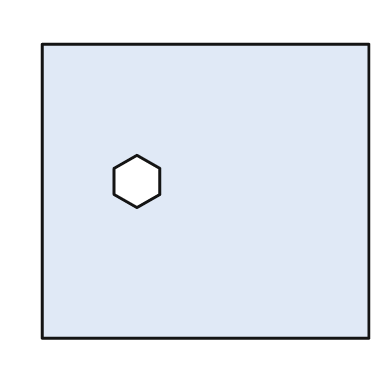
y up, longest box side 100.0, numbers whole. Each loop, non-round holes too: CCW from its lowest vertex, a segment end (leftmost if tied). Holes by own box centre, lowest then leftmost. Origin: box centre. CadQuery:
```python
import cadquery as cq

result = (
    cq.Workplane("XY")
    .moveTo(-50.0, -45.0)
    .lineTo(50.0, -45.0)
    .lineTo(50.0, 45.0)
    .lineTo(-50.0, 45.0)
    .close()
    .moveTo(-21.0, -5.0)
    .lineTo(-14.0, -1.0)
    .lineTo(-14.0, 7.0)
    .lineTo(-21.0, 11.0)
    .lineTo(-28.0, 7.0)
    .lineTo(-28.0, -1.0)
    .close()
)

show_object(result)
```